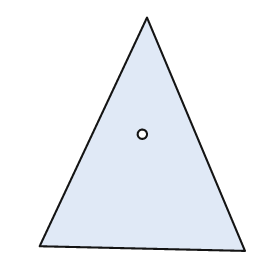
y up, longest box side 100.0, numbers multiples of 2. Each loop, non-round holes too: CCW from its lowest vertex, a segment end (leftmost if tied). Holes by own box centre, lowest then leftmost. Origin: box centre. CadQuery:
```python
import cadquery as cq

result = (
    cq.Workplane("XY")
    .moveTo(44.0, -50.0)
    .lineTo(2.0, 50.0)
    .lineTo(-44.0, -48.0)
    .close()
    .moveTo(0.0, 0.0)
    .circle(2.0)
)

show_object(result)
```